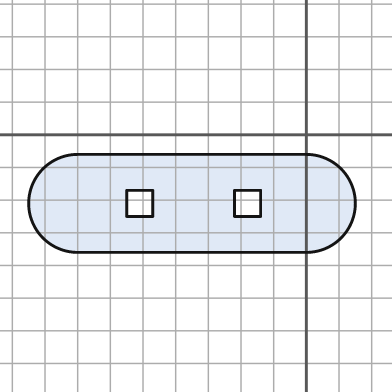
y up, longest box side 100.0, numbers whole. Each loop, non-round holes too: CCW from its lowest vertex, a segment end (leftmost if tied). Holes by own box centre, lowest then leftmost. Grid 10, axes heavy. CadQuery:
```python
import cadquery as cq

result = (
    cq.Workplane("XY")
    .moveTo(-70.0, -36.0)
    .lineTo(0.0, -36.0)
    .threePointArc((15.0, -21.0), (0.0, -6.0))
    .lineTo(-70.0, -6.0)
    .threePointArc((-85.0, -21.0), (-70.0, -36.0))
    .close()
    .moveTo(-55.0, -25.0)
    .lineTo(-47.0, -25.0)
    .lineTo(-47.0, -17.0)
    .lineTo(-55.0, -17.0)
    .close()
    .moveTo(-22.0, -25.0)
    .lineTo(-14.0, -25.0)
    .lineTo(-14.0, -17.0)
    .lineTo(-22.0, -17.0)
    .close()
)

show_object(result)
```